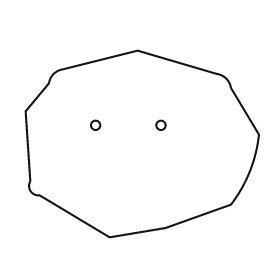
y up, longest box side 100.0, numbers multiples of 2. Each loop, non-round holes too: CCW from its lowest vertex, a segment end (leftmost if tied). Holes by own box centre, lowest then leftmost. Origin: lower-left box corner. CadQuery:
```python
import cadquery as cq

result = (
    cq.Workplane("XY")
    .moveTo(36.0, 0.0)
    .lineTo(60.0, 4.0)
    .lineTo(88.0, 14.0)
    .threePointArc((96.0, 28.0), (100.0, 44.0))
    .lineTo(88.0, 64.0)
    .threePointArc((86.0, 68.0), (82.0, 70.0))
    .lineTo(48.0, 80.0)
    .lineTo(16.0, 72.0)
    .threePointArc((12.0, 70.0), (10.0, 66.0))
    .lineTo(0.0, 54.0)
    .lineTo(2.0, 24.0)
    .threePointArc((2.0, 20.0), (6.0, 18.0))
    .close()
    .moveTo(30.0, 48.0)
    .circle(2.0)
    .moveTo(58.0, 48.0)
    .circle(2.0)
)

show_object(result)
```